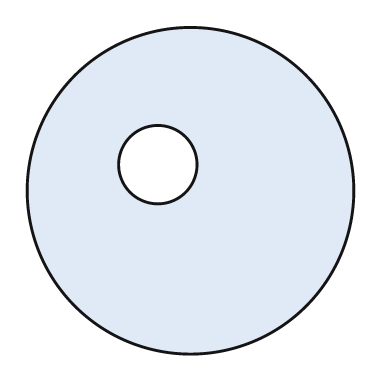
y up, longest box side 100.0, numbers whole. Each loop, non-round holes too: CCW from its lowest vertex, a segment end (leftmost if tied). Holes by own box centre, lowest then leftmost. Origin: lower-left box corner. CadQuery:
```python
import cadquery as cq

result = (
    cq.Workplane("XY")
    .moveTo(50.0, 50.0)
    .circle(50.0)
    .moveTo(40.0, 58.0)
    .circle(12.0)
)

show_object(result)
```